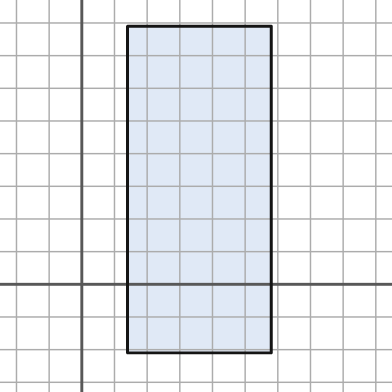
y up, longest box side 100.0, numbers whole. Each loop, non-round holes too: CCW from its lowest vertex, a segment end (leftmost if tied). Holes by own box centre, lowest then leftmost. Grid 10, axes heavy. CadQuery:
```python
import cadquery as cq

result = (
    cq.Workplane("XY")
    .moveTo(14.0, -21.0)
    .lineTo(58.0, -21.0)
    .lineTo(58.0, 79.0)
    .lineTo(14.0, 79.0)
    .close()
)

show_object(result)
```